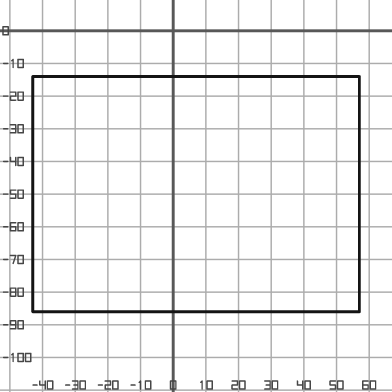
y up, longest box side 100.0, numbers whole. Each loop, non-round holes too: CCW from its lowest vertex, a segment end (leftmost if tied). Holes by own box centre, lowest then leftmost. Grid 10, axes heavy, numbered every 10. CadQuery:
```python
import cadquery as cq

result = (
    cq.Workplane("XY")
    .moveTo(-43.0, -86.0)
    .lineTo(57.0, -86.0)
    .lineTo(57.0, -14.0)
    .lineTo(-43.0, -14.0)
    .close()
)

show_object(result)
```